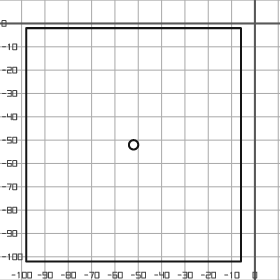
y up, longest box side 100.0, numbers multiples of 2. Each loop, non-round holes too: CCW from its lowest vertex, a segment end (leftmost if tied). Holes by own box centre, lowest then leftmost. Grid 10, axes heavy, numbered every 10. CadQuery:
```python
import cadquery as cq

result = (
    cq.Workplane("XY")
    .moveTo(-98.0, -102.0)
    .lineTo(-6.0, -102.0)
    .lineTo(-6.0, -2.0)
    .lineTo(-98.0, -2.0)
    .close()
    .moveTo(-52.0, -52.0)
    .circle(2.0)
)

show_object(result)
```